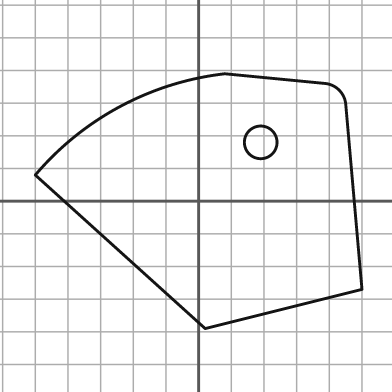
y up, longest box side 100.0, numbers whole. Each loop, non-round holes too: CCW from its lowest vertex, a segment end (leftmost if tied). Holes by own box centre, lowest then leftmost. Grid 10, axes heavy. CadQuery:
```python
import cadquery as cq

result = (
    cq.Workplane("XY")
    .moveTo(2.0, -39.0)
    .lineTo(50.0, -27.0)
    .lineTo(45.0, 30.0)
    .threePointArc((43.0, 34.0), (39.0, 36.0))
    .lineTo(8.0, 39.0)
    .threePointArc((-24.0, 29.0), (-50.0, 8.0))
    .close()
    .moveTo(19.0, 18.0)
    .circle(5.0)
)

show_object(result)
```